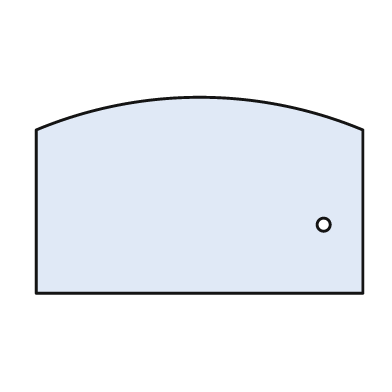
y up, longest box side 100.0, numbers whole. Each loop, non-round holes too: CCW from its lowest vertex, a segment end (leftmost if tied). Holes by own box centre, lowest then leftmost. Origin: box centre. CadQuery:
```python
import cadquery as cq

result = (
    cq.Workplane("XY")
    .moveTo(-50.0, -30.0)
    .lineTo(50.0, -30.0)
    .lineTo(50.0, 20.0)
    .threePointArc((0.0, 30.0), (-50.0, 20.0))
    .close()
    .moveTo(38.0, -9.0)
    .circle(2.0)
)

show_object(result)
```